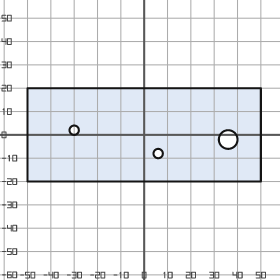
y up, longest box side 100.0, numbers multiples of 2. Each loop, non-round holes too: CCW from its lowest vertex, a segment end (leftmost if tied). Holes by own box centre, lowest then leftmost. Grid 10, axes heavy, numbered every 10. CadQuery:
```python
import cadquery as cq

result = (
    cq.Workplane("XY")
    .moveTo(-50.0, -20.0)
    .lineTo(50.0, -20.0)
    .lineTo(50.0, 20.0)
    .lineTo(-50.0, 20.0)
    .close()
    .moveTo(6.0, -8.0)
    .circle(2.0)
    .moveTo(36.0, -2.0)
    .circle(4.0)
    .moveTo(-30.0, 2.0)
    .circle(2.0)
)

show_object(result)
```